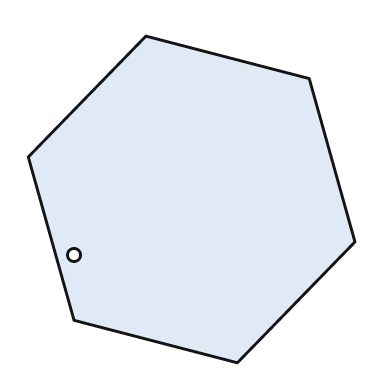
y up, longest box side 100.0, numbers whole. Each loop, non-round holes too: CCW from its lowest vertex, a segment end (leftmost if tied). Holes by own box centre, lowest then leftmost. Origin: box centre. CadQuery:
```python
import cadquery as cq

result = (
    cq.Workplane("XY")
    .moveTo(14.0, -50.0)
    .lineTo(50.0, -13.0)
    .lineTo(36.0, 37.0)
    .lineTo(-14.0, 50.0)
    .lineTo(-50.0, 13.0)
    .lineTo(-36.0, -37.0)
    .close()
    .moveTo(-36.0, -17.0)
    .circle(2.0)
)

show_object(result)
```